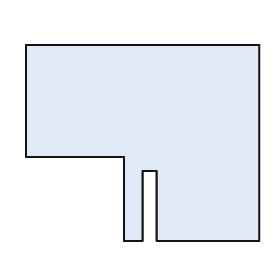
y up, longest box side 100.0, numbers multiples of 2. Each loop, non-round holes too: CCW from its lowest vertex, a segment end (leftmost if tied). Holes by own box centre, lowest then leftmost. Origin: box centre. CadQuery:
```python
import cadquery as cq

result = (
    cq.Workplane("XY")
    .moveTo(-8.0, -42.0)
    .lineTo(0.0, -42.0)
    .lineTo(0.0, -12.0)
    .lineTo(6.0, -12.0)
    .lineTo(6.0, -42.0)
    .lineTo(50.0, -42.0)
    .lineTo(50.0, 42.0)
    .lineTo(-50.0, 42.0)
    .lineTo(-50.0, -6.0)
    .lineTo(-8.0, -6.0)
    .close()
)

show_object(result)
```